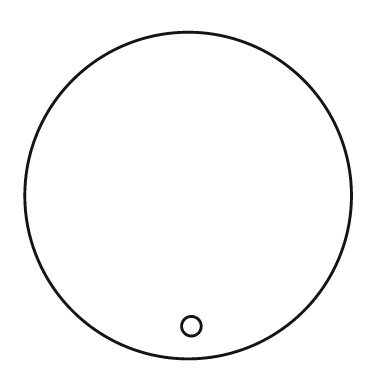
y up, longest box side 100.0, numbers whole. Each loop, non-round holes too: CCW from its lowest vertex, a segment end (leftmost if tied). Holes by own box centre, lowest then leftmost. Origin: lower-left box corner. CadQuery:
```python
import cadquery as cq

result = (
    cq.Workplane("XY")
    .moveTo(50.0, 50.0)
    .circle(50.0)
    .moveTo(51.0, 10.0)
    .circle(3.0)
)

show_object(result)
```